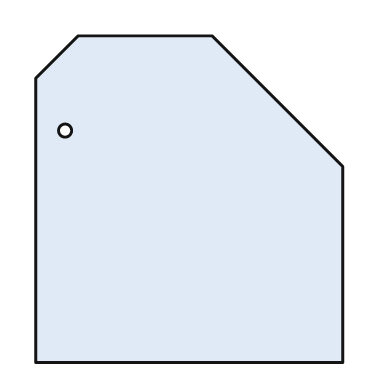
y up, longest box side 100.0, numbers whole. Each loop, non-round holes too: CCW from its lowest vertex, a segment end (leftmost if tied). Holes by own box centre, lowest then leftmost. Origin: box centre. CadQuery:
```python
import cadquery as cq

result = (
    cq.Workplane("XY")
    .moveTo(-47.0, -50.0)
    .lineTo(47.0, -50.0)
    .lineTo(47.0, 10.0)
    .lineTo(7.0, 50.0)
    .lineTo(-34.0, 50.0)
    .lineTo(-47.0, 37.0)
    .close()
    .moveTo(-38.0, 21.0)
    .circle(2.0)
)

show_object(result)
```